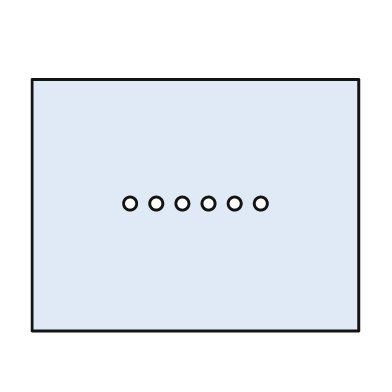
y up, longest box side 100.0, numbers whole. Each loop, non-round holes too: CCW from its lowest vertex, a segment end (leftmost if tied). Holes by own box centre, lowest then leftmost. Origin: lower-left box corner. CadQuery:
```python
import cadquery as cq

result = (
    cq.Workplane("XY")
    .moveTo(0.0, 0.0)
    .lineTo(100.0, 0.0)
    .lineTo(100.0, 77.0)
    .lineTo(0.0, 77.0)
    .close()
    .moveTo(30.0, 39.0)
    .circle(2.0)
    .moveTo(38.0, 39.0)
    .circle(2.0)
    .moveTo(46.0, 39.0)
    .circle(2.0)
    .moveTo(54.0, 39.0)
    .circle(2.0)
    .moveTo(62.0, 39.0)
    .circle(2.0)
    .moveTo(70.0, 39.0)
    .circle(2.0)
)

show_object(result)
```